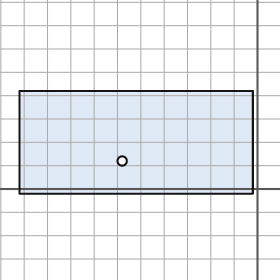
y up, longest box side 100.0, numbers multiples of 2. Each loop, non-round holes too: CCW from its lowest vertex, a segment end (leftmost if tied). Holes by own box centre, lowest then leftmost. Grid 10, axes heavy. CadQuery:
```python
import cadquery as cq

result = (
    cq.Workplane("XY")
    .moveTo(-102.0, -2.0)
    .lineTo(-2.0, -2.0)
    .lineTo(-2.0, 42.0)
    .lineTo(-102.0, 42.0)
    .close()
    .moveTo(-58.0, 12.0)
    .circle(2.0)
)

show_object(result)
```